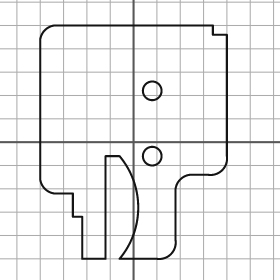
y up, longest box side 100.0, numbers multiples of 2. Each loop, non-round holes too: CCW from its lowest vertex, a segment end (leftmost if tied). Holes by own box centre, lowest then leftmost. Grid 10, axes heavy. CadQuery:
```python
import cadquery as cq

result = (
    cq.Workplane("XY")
    .moveTo(-22.0, -50.0)
    .lineTo(-12.0, -50.0)
    .lineTo(-12.0, -6.0)
    .lineTo(-6.0, -6.0)
    .threePointArc((2.0, -28.0), (-6.0, -50.0))
    .lineTo(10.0, -50.0)
    .threePointArc((16.0, -48.0), (18.0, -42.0))
    .lineTo(18.0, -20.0)
    .threePointArc((20.0, -16.0), (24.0, -14.0))
    .lineTo(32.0, -14.0)
    .threePointArc((38.0, -12.0), (40.0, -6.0))
    .lineTo(40.0, 46.0)
    .lineTo(34.0, 46.0)
    .lineTo(34.0, 50.0)
    .lineTo(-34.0, 50.0)
    .threePointArc((-38.0, 48.0), (-40.0, 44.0))
    .lineTo(-40.0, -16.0)
    .threePointArc((-38.0, -20.0), (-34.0, -22.0))
    .lineTo(-26.0, -22.0)
    .lineTo(-26.0, -32.0)
    .lineTo(-22.0, -32.0)
    .close()
    .moveTo(8.0, -6.0)
    .circle(4.0)
    .moveTo(8.0, 22.0)
    .circle(4.0)
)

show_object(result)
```